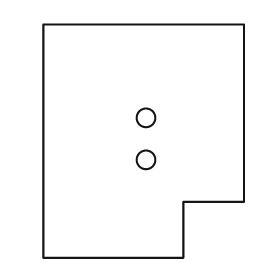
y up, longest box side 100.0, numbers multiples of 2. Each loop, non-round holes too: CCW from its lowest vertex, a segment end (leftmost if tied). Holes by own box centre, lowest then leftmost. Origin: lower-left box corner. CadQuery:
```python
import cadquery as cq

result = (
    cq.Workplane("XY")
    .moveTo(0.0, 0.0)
    .lineTo(60.0, 0.0)
    .lineTo(60.0, 24.0)
    .lineTo(86.0, 24.0)
    .lineTo(86.0, 100.0)
    .lineTo(0.0, 100.0)
    .close()
    .moveTo(44.0, 42.0)
    .circle(4.0)
    .moveTo(44.0, 60.0)
    .circle(4.0)
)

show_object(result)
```